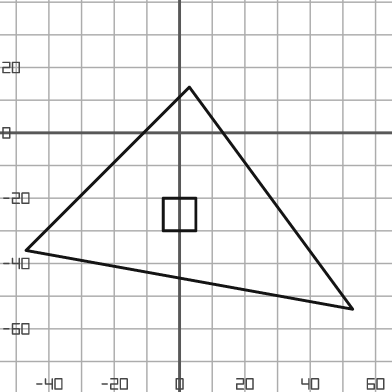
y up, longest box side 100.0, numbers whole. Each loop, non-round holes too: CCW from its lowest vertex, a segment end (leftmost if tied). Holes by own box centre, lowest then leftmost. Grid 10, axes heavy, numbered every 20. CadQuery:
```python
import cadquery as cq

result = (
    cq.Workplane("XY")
    .moveTo(53.0, -54.0)
    .lineTo(3.0, 14.0)
    .lineTo(-47.0, -36.0)
    .close()
    .moveTo(-5.0, -30.0)
    .lineTo(5.0, -30.0)
    .lineTo(5.0, -20.0)
    .lineTo(-5.0, -20.0)
    .close()
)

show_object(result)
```